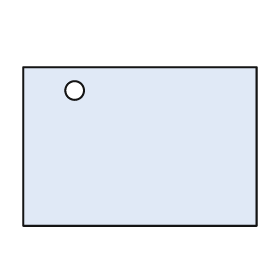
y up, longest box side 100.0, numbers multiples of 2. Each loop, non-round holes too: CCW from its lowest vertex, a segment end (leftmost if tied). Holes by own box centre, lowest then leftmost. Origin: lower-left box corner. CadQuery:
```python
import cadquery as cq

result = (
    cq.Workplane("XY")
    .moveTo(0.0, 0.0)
    .lineTo(100.0, 0.0)
    .lineTo(100.0, 68.0)
    .lineTo(0.0, 68.0)
    .close()
    .moveTo(22.0, 58.0)
    .circle(4.0)
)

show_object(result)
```